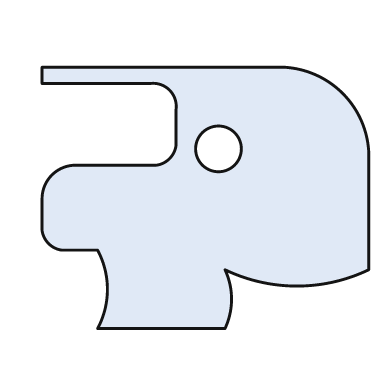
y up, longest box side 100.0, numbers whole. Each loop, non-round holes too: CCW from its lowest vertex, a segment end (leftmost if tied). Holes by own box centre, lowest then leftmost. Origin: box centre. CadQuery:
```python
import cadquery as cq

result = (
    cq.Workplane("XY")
    .moveTo(-33.0, -40.0)
    .lineTo(6.0, -40.0)
    .threePointArc((8.0, -31.0), (6.0, -22.0))
    .threePointArc((28.0, -27.0), (50.0, -22.0))
    .lineTo(50.0, 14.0)
    .threePointArc((42.0, 32.0), (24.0, 40.0))
    .lineTo(-50.0, 40.0)
    .lineTo(-50.0, 35.0)
    .lineTo(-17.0, 35.0)
    .threePointArc((-11.0, 33.0), (-9.0, 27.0))
    .lineTo(-9.0, 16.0)
    .threePointArc((-11.0, 12.0), (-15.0, 10.0))
    .lineTo(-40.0, 10.0)
    .threePointArc((-47.0, 7.0), (-50.0, 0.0))
    .lineTo(-50.0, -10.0)
    .threePointArc((-48.0, -14.0), (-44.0, -16.0))
    .lineTo(-33.0, -16.0)
    .threePointArc((-30.0, -28.0), (-33.0, -40.0))
    .close()
    .moveTo(4.0, 15.0)
    .circle(7.0)
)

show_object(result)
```